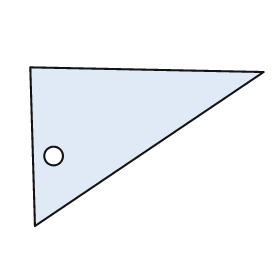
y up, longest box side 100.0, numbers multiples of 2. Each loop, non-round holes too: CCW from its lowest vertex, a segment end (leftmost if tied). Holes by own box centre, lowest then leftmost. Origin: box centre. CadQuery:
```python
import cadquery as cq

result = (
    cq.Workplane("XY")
    .moveTo(-48.0, -34.0)
    .lineTo(50.0, 32.0)
    .lineTo(-50.0, 34.0)
    .close()
    .moveTo(-40.0, -4.0)
    .circle(4.0)
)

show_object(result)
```